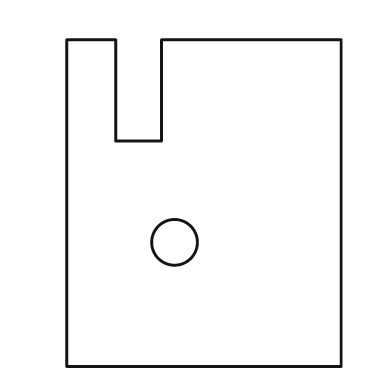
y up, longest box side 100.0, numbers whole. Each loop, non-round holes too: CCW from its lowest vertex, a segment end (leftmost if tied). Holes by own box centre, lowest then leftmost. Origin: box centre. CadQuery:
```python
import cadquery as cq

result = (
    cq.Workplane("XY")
    .moveTo(-42.0, -50.0)
    .lineTo(42.0, -50.0)
    .lineTo(42.0, 50.0)
    .lineTo(-13.0, 50.0)
    .lineTo(-13.0, 19.0)
    .lineTo(-27.0, 19.0)
    .lineTo(-27.0, 50.0)
    .lineTo(-42.0, 50.0)
    .close()
    .moveTo(-9.0, -12.0)
    .circle(7.0)
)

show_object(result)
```